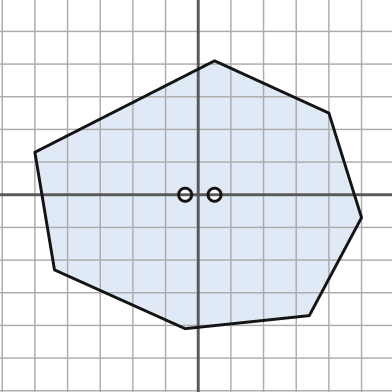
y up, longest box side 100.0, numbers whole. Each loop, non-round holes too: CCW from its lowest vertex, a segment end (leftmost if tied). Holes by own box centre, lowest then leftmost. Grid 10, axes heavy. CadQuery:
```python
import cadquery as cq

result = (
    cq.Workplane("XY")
    .moveTo(-4.0, -41.0)
    .lineTo(34.0, -37.0)
    .lineTo(50.0, -7.0)
    .lineTo(40.0, 25.0)
    .lineTo(5.0, 41.0)
    .lineTo(-50.0, 13.0)
    .lineTo(-44.0, -23.0)
    .close()
    .moveTo(-4.0, 0.0)
    .circle(2.0)
    .moveTo(5.0, 0.0)
    .circle(2.0)
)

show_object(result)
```